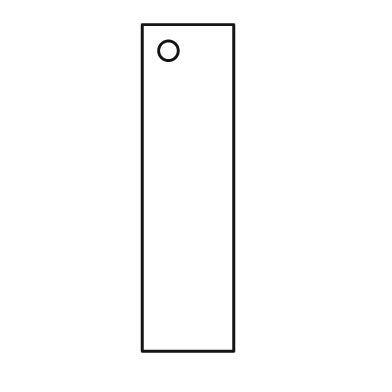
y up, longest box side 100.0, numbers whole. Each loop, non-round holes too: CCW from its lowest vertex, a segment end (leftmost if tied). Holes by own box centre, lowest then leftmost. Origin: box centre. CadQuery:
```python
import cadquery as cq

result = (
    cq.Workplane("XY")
    .moveTo(-14.0, -50.0)
    .lineTo(14.0, -50.0)
    .lineTo(14.0, 50.0)
    .lineTo(-14.0, 50.0)
    .close()
    .moveTo(-6.0, 42.0)
    .circle(3.0)
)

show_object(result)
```